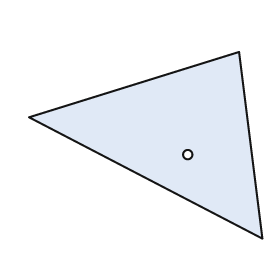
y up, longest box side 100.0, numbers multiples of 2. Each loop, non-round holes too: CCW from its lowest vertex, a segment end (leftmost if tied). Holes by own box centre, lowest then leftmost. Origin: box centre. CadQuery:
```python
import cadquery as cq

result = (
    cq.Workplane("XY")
    .moveTo(50.0, -40.0)
    .lineTo(40.0, 40.0)
    .lineTo(-50.0, 12.0)
    .close()
    .moveTo(18.0, -4.0)
    .circle(2.0)
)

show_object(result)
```